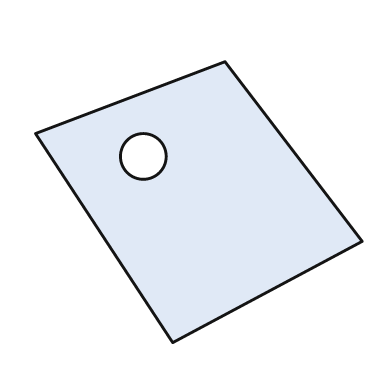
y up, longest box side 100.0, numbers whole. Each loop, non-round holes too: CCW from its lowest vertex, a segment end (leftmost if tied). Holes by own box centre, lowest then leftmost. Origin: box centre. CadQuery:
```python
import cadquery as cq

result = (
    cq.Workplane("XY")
    .moveTo(-8.0, -43.0)
    .lineTo(50.0, -12.0)
    .lineTo(8.0, 43.0)
    .lineTo(-50.0, 21.0)
    .close()
    .moveTo(-17.0, 14.0)
    .circle(7.0)
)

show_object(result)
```